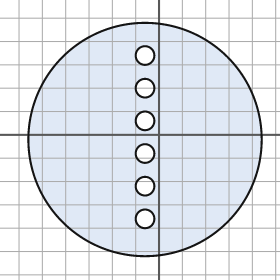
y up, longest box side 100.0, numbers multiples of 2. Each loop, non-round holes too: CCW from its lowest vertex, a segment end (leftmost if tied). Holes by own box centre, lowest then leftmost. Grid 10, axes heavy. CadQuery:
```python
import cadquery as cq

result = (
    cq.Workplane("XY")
    .moveTo(-6.0, -2.0)
    .circle(50.0)
    .moveTo(-6.0, -36.0)
    .circle(4.0)
    .moveTo(-6.0, -22.0)
    .circle(4.0)
    .moveTo(-6.0, -8.0)
    .circle(4.0)
    .moveTo(-6.0, 6.0)
    .circle(4.0)
    .moveTo(-6.0, 20.0)
    .circle(4.0)
    .moveTo(-6.0, 34.0)
    .circle(4.0)
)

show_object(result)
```